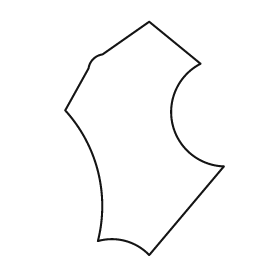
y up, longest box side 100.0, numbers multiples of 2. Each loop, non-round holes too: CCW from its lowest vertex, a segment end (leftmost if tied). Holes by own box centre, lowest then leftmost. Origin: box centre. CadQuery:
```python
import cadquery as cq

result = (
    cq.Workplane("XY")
    .moveTo(2.0, -50.0)
    .lineTo(34.0, -12.0)
    .threePointArc((12.0, 6.0), (24.0, 32.0))
    .lineTo(2.0, 50.0)
    .lineTo(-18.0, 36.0)
    .threePointArc((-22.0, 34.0), (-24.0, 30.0))
    .lineTo(-34.0, 12.0)
    .threePointArc((-20.0, -14.0), (-20.0, -44.0))
    .threePointArc((-8.0, -44.0), (2.0, -50.0))
    .close()
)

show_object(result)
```